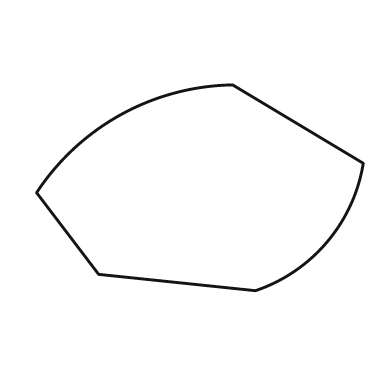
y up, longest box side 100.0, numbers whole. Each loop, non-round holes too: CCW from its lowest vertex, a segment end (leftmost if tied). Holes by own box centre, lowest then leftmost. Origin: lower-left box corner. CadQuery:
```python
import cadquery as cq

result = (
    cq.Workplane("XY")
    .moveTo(67.0, 0.0)
    .threePointArc((89.0, 15.0), (100.0, 39.0))
    .lineTo(60.0, 63.0)
    .threePointArc((26.0, 54.0), (0.0, 30.0))
    .lineTo(19.0, 5.0)
    .close()
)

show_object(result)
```